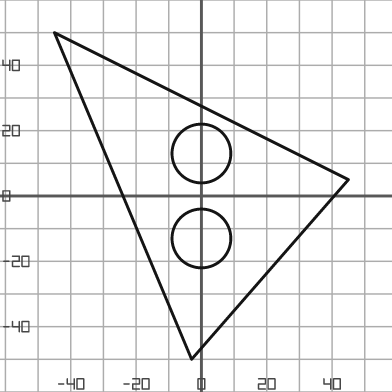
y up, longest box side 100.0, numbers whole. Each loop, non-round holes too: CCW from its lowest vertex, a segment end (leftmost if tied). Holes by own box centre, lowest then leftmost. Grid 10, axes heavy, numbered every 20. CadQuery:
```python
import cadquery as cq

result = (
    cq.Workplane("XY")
    .moveTo(-3.0, -50.0)
    .lineTo(45.0, 5.0)
    .lineTo(-45.0, 50.0)
    .close()
    .moveTo(0.0, -13.0)
    .circle(9.0)
    .moveTo(0.0, 13.0)
    .circle(9.0)
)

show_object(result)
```